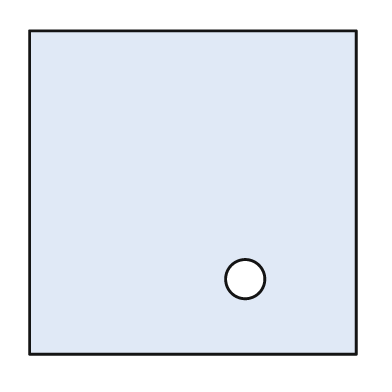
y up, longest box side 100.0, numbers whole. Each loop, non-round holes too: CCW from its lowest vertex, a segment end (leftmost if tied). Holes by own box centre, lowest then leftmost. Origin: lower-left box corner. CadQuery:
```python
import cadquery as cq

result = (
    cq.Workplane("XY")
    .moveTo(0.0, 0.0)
    .lineTo(100.0, 0.0)
    .lineTo(100.0, 99.0)
    .lineTo(0.0, 99.0)
    .close()
    .moveTo(66.0, 23.0)
    .circle(6.0)
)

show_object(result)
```